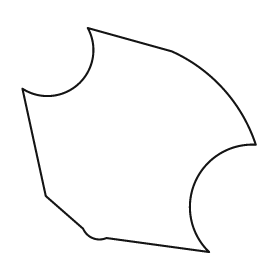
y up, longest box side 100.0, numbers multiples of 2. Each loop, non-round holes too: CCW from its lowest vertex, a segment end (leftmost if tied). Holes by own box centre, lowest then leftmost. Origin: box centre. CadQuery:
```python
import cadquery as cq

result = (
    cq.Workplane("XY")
    .moveTo(30.0, -48.0)
    .threePointArc((24.0, -18.0), (50.0, -2.0))
    .threePointArc((36.0, 22.0), (14.0, 38.0))
    .lineTo(-22.0, 48.0)
    .threePointArc((-26.0, 24.0), (-50.0, 22.0))
    .lineTo(-40.0, -24.0)
    .lineTo(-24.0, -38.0)
    .threePointArc((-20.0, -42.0), (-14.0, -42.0))
    .close()
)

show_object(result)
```